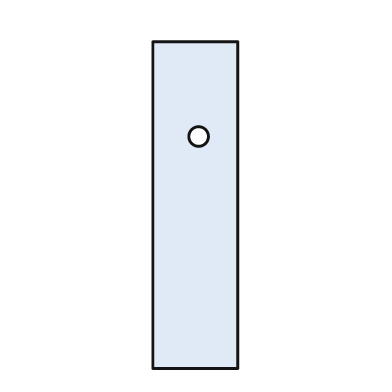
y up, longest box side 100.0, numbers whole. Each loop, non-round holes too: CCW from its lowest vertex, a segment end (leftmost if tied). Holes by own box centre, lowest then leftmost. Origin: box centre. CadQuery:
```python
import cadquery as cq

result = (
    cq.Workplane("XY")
    .moveTo(-13.0, -50.0)
    .lineTo(13.0, -50.0)
    .lineTo(13.0, 50.0)
    .lineTo(-13.0, 50.0)
    .close()
    .moveTo(1.0, 21.0)
    .circle(3.0)
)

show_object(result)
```